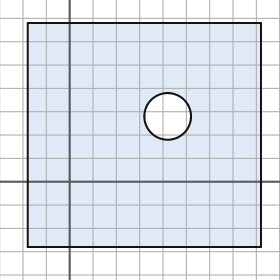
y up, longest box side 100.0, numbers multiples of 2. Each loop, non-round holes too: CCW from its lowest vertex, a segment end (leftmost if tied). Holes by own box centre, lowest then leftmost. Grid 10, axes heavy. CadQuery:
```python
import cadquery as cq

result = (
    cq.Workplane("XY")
    .moveTo(-18.0, -28.0)
    .lineTo(82.0, -28.0)
    .lineTo(82.0, 68.0)
    .lineTo(-18.0, 68.0)
    .close()
    .moveTo(42.0, 28.0)
    .circle(10.0)
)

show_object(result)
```